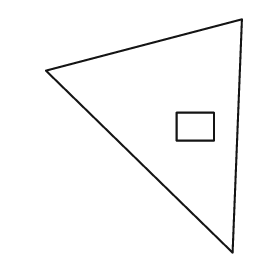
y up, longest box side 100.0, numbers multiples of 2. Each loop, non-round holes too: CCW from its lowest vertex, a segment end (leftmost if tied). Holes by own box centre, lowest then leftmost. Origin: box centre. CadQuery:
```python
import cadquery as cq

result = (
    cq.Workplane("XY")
    .moveTo(38.0, -50.0)
    .lineTo(42.0, 50.0)
    .lineTo(-42.0, 28.0)
    .close()
    .moveTo(14.0, -2.0)
    .lineTo(30.0, -2.0)
    .lineTo(30.0, 10.0)
    .lineTo(14.0, 10.0)
    .close()
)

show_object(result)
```